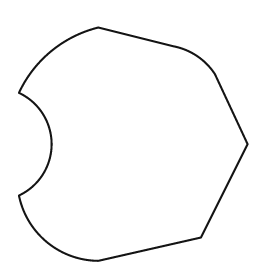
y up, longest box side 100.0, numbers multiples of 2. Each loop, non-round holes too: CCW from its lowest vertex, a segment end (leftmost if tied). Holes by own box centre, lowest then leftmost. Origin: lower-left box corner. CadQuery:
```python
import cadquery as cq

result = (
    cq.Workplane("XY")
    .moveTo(34.0, 0.0)
    .lineTo(78.0, 10.0)
    .lineTo(98.0, 50.0)
    .lineTo(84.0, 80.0)
    .threePointArc((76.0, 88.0), (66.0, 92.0))
    .lineTo(34.0, 100.0)
    .threePointArc((14.0, 90.0), (0.0, 72.0))
    .threePointArc((14.0, 50.0), (0.0, 28.0))
    .threePointArc((12.0, 8.0), (34.0, 0.0))
    .close()
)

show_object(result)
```